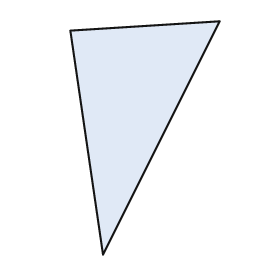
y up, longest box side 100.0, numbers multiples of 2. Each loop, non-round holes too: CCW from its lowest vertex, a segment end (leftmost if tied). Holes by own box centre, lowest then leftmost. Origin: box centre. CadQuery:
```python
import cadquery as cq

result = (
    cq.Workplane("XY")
    .moveTo(-18.0, -50.0)
    .lineTo(32.0, 50.0)
    .lineTo(-32.0, 46.0)
    .close()
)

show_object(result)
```